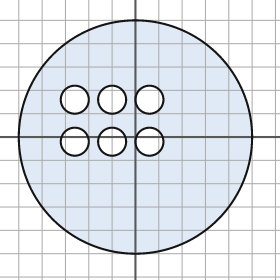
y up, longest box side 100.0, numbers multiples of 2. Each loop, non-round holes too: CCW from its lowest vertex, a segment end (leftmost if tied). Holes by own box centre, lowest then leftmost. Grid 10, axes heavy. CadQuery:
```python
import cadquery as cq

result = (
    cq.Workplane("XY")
    .moveTo(0.0, 0.0)
    .circle(50.0)
    .moveTo(-26.0, -2.0)
    .circle(6.0)
    .moveTo(-10.0, -2.0)
    .circle(6.0)
    .moveTo(6.0, -2.0)
    .circle(6.0)
    .moveTo(-26.0, 16.0)
    .circle(6.0)
    .moveTo(-10.0, 16.0)
    .circle(6.0)
    .moveTo(6.0, 16.0)
    .circle(6.0)
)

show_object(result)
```